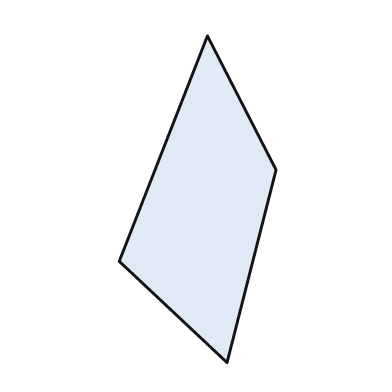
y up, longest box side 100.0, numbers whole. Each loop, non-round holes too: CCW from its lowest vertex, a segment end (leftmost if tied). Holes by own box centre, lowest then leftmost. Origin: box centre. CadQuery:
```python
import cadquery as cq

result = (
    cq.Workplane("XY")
    .moveTo(9.0, -50.0)
    .lineTo(24.0, 9.0)
    .lineTo(3.0, 50.0)
    .lineTo(-24.0, -19.0)
    .close()
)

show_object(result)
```